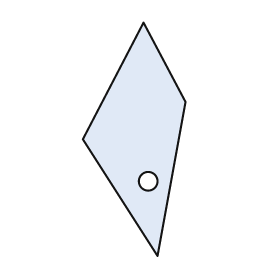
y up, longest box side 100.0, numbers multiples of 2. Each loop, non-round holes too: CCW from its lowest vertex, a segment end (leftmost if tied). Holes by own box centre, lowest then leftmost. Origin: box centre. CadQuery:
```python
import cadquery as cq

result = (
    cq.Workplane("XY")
    .moveTo(10.0, -50.0)
    .lineTo(22.0, 16.0)
    .lineTo(4.0, 50.0)
    .lineTo(-22.0, 0.0)
    .close()
    .moveTo(6.0, -18.0)
    .circle(4.0)
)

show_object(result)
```